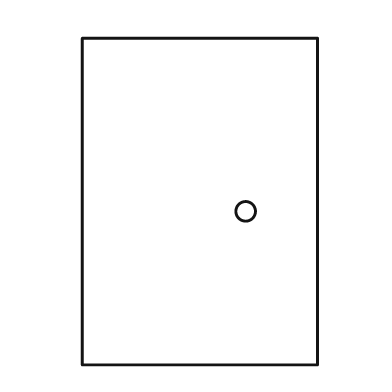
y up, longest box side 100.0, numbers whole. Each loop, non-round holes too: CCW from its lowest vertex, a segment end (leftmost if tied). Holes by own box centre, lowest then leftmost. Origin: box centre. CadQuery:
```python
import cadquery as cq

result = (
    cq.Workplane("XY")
    .moveTo(-36.0, -50.0)
    .lineTo(36.0, -50.0)
    .lineTo(36.0, 50.0)
    .lineTo(-36.0, 50.0)
    .close()
    .moveTo(14.0, -3.0)
    .circle(3.0)
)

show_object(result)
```